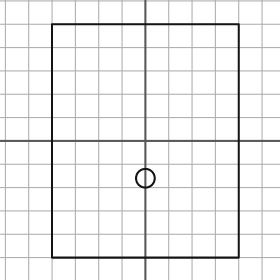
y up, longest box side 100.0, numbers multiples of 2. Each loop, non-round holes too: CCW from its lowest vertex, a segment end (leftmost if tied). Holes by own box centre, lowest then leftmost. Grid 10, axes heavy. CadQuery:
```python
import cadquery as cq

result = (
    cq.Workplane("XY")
    .moveTo(-40.0, -50.0)
    .lineTo(40.0, -50.0)
    .lineTo(40.0, 50.0)
    .lineTo(-40.0, 50.0)
    .close()
    .moveTo(0.0, -16.0)
    .circle(4.0)
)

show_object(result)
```